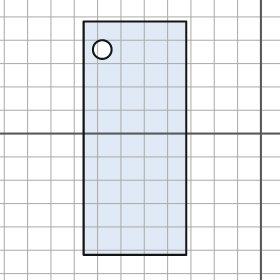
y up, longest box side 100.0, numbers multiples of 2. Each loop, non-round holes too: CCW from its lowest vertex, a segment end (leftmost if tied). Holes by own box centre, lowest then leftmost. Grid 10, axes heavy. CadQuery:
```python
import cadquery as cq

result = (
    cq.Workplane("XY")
    .moveTo(-76.0, -52.0)
    .lineTo(-32.0, -52.0)
    .lineTo(-32.0, 48.0)
    .lineTo(-76.0, 48.0)
    .close()
    .moveTo(-68.0, 36.0)
    .circle(4.0)
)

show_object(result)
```